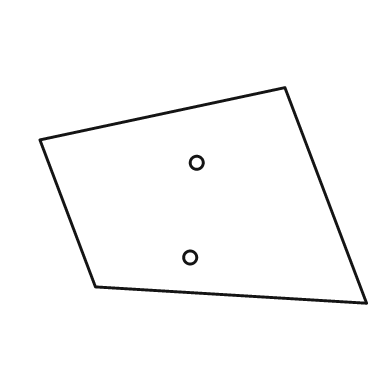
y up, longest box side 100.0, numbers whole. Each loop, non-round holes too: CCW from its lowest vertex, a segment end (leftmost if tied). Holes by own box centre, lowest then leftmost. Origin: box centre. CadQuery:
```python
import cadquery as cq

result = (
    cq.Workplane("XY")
    .moveTo(50.0, -33.0)
    .lineTo(25.0, 33.0)
    .lineTo(-50.0, 17.0)
    .lineTo(-33.0, -28.0)
    .close()
    .moveTo(-4.0, -19.0)
    .circle(2.0)
    .moveTo(-2.0, 10.0)
    .circle(2.0)
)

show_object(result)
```